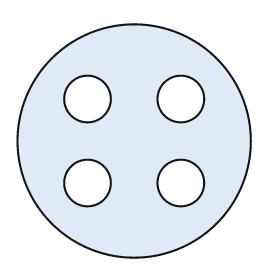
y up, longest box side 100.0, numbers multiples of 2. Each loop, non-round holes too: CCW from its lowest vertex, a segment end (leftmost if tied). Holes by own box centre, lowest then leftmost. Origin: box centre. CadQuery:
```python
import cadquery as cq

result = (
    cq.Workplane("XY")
    .moveTo(0.0, 0.0)
    .circle(50.0)
    .moveTo(-20.0, -18.0)
    .circle(10.0)
    .moveTo(20.0, -18.0)
    .circle(10.0)
    .moveTo(-20.0, 18.0)
    .circle(10.0)
    .moveTo(20.0, 18.0)
    .circle(10.0)
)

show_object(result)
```